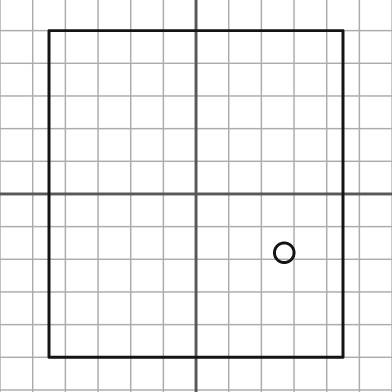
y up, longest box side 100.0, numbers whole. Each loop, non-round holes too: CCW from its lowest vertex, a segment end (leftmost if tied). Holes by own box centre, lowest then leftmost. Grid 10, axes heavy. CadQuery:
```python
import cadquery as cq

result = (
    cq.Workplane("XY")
    .moveTo(-45.0, -50.0)
    .lineTo(45.0, -50.0)
    .lineTo(45.0, 50.0)
    .lineTo(-45.0, 50.0)
    .close()
    .moveTo(27.0, -18.0)
    .circle(3.0)
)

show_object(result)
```